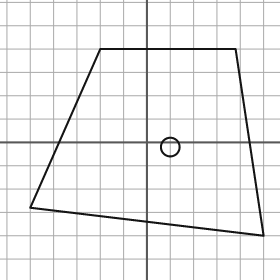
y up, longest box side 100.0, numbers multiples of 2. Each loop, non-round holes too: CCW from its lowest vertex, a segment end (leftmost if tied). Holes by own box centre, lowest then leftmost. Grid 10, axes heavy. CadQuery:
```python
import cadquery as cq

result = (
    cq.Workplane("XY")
    .moveTo(50.0, -40.0)
    .lineTo(38.0, 40.0)
    .lineTo(-20.0, 40.0)
    .lineTo(-50.0, -28.0)
    .close()
    .moveTo(10.0, -2.0)
    .circle(4.0)
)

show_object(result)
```